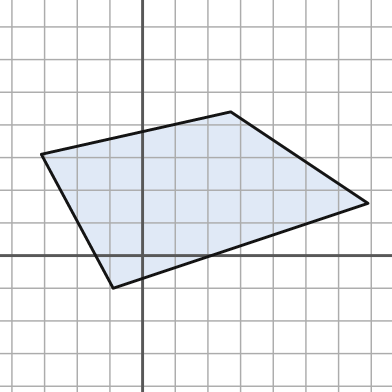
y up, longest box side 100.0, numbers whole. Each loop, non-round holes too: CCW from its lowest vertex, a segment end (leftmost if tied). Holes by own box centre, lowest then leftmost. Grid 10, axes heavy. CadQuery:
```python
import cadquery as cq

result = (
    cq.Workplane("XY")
    .moveTo(-9.0, -10.0)
    .lineTo(69.0, 16.0)
    .lineTo(27.0, 44.0)
    .lineTo(-31.0, 31.0)
    .close()
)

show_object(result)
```